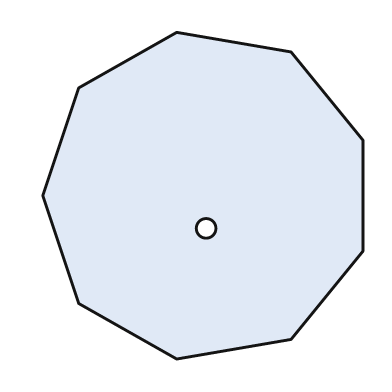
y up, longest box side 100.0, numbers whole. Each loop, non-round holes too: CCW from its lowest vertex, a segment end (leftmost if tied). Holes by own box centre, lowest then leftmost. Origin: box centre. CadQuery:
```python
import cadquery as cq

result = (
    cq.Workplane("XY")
    .moveTo(-8.0, -50.0)
    .lineTo(27.0, -44.0)
    .lineTo(49.0, -17.0)
    .lineTo(49.0, 17.0)
    .lineTo(27.0, 44.0)
    .lineTo(-8.0, 50.0)
    .lineTo(-38.0, 33.0)
    .lineTo(-49.0, 0.0)
    .lineTo(-38.0, -33.0)
    .close()
    .moveTo(1.0, -10.0)
    .circle(3.0)
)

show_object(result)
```